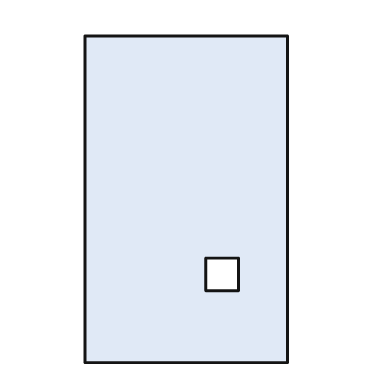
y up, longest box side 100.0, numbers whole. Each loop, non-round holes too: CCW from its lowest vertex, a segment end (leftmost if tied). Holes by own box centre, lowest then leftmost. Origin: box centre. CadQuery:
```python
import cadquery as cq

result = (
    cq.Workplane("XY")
    .moveTo(-31.0, -50.0)
    .lineTo(31.0, -50.0)
    .lineTo(31.0, 50.0)
    .lineTo(-31.0, 50.0)
    .close()
    .moveTo(6.0, -28.0)
    .lineTo(16.0, -28.0)
    .lineTo(16.0, -18.0)
    .lineTo(6.0, -18.0)
    .close()
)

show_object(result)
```